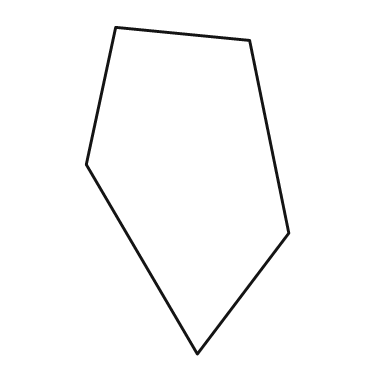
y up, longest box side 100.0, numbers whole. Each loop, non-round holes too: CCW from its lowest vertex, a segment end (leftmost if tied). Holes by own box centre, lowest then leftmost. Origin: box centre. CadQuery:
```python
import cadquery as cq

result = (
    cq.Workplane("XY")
    .moveTo(3.0, -50.0)
    .lineTo(31.0, -13.0)
    .lineTo(19.0, 46.0)
    .lineTo(-22.0, 50.0)
    .lineTo(-31.0, 8.0)
    .close()
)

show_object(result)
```